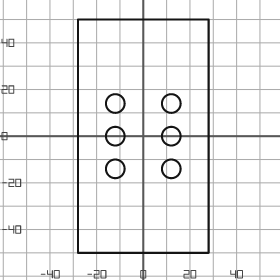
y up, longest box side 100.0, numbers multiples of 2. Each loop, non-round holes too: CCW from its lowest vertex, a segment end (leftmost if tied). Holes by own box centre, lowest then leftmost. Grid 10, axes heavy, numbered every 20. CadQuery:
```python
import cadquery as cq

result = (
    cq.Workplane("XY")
    .moveTo(-28.0, -50.0)
    .lineTo(28.0, -50.0)
    .lineTo(28.0, 50.0)
    .lineTo(-28.0, 50.0)
    .close()
    .moveTo(-12.0, -14.0)
    .circle(4.0)
    .moveTo(12.0, -14.0)
    .circle(4.0)
    .moveTo(-12.0, 0.0)
    .circle(4.0)
    .moveTo(12.0, 0.0)
    .circle(4.0)
    .moveTo(-12.0, 14.0)
    .circle(4.0)
    .moveTo(12.0, 14.0)
    .circle(4.0)
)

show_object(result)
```